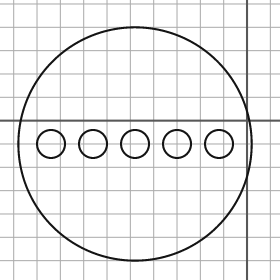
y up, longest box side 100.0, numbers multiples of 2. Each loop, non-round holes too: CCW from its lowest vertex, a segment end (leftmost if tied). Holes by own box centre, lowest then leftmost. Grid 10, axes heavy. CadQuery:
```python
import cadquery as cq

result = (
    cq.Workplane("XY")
    .moveTo(-48.0, -10.0)
    .circle(50.0)
    .moveTo(-84.0, -10.0)
    .circle(6.0)
    .moveTo(-66.0, -10.0)
    .circle(6.0)
    .moveTo(-48.0, -10.0)
    .circle(6.0)
    .moveTo(-30.0, -10.0)
    .circle(6.0)
    .moveTo(-12.0, -10.0)
    .circle(6.0)
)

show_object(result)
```